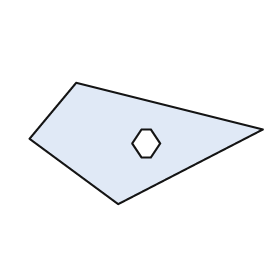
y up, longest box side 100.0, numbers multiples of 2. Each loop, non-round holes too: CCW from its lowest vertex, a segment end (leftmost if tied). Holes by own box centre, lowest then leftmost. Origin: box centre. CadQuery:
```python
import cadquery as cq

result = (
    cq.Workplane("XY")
    .moveTo(-12.0, -26.0)
    .lineTo(50.0, 6.0)
    .lineTo(-30.0, 26.0)
    .lineTo(-50.0, 2.0)
    .close()
    .moveTo(-2.0, -6.0)
    .lineTo(2.0, -6.0)
    .lineTo(6.0, 0.0)
    .lineTo(2.0, 6.0)
    .lineTo(-2.0, 6.0)
    .lineTo(-6.0, 0.0)
    .close()
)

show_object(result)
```